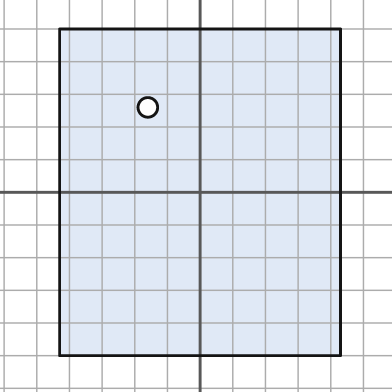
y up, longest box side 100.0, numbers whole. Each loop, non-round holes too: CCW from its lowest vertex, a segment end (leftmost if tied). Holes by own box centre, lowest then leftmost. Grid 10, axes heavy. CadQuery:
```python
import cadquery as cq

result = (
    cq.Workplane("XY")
    .moveTo(-43.0, -50.0)
    .lineTo(43.0, -50.0)
    .lineTo(43.0, 50.0)
    .lineTo(-43.0, 50.0)
    .close()
    .moveTo(-16.0, 26.0)
    .circle(3.0)
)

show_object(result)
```